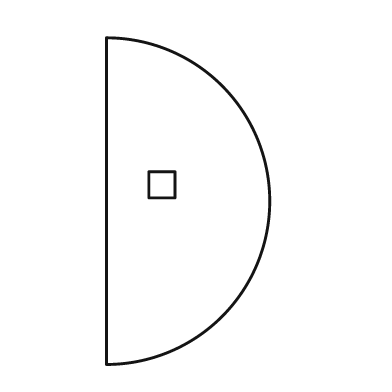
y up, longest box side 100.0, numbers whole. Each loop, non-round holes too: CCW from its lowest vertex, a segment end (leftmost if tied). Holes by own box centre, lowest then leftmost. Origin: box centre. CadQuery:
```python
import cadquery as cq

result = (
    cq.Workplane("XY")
    .moveTo(-25.0, -50.0)
    .threePointArc((25.0, 0.0), (-25.0, 50.0))
    .close()
    .moveTo(-12.0, 1.0)
    .lineTo(-4.0, 1.0)
    .lineTo(-4.0, 9.0)
    .lineTo(-12.0, 9.0)
    .close()
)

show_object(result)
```